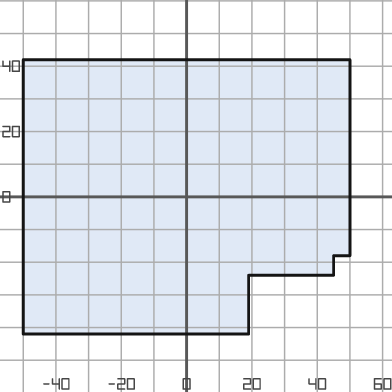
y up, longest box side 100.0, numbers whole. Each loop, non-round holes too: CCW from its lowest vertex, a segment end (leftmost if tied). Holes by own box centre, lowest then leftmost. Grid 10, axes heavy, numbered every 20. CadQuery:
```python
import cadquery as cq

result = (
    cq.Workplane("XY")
    .moveTo(-50.0, -42.0)
    .lineTo(19.0, -42.0)
    .lineTo(19.0, -24.0)
    .lineTo(45.0, -24.0)
    .lineTo(45.0, -18.0)
    .lineTo(50.0, -18.0)
    .lineTo(50.0, 42.0)
    .lineTo(-50.0, 42.0)
    .close()
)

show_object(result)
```